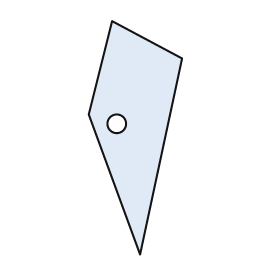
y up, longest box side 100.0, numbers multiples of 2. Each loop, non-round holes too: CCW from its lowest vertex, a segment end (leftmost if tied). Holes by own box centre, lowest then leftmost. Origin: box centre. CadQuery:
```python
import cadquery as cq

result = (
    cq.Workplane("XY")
    .moveTo(2.0, -50.0)
    .lineTo(20.0, 34.0)
    .lineTo(-10.0, 50.0)
    .lineTo(-20.0, 10.0)
    .close()
    .moveTo(-8.0, 6.0)
    .circle(4.0)
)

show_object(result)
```